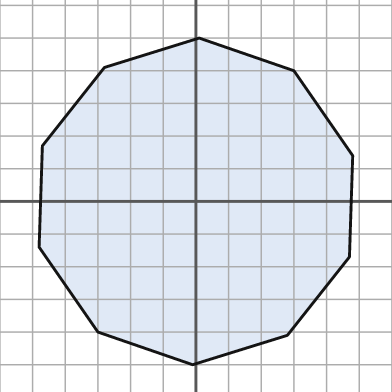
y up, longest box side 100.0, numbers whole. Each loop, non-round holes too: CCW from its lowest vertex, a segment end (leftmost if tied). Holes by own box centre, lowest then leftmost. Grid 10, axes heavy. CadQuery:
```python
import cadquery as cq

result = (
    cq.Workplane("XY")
    .moveTo(-1.0, -50.0)
    .lineTo(28.0, -41.0)
    .lineTo(47.0, -17.0)
    .lineTo(48.0, 14.0)
    .lineTo(30.0, 40.0)
    .lineTo(1.0, 50.0)
    .lineTo(-28.0, 41.0)
    .lineTo(-47.0, 17.0)
    .lineTo(-48.0, -14.0)
    .lineTo(-30.0, -40.0)
    .close()
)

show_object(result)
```